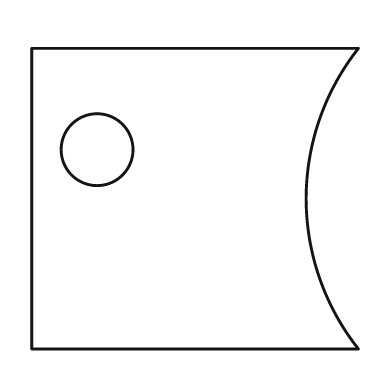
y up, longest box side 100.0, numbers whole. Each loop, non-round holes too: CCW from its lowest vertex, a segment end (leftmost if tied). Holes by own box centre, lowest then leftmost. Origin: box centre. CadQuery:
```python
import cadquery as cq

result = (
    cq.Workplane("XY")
    .moveTo(-50.0, -46.0)
    .lineTo(50.0, -46.0)
    .threePointArc((34.0, 0.0), (50.0, 46.0))
    .lineTo(-50.0, 46.0)
    .close()
    .moveTo(-30.0, 15.0)
    .circle(11.0)
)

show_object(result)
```